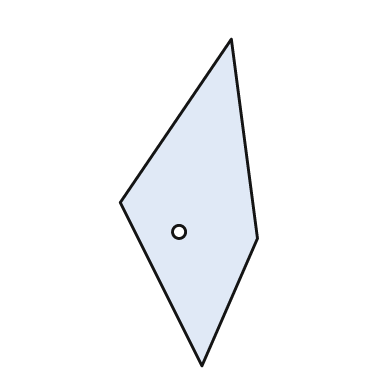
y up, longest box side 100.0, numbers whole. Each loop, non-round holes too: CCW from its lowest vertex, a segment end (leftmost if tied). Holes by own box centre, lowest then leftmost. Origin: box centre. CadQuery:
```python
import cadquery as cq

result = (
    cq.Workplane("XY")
    .moveTo(4.0, -50.0)
    .lineTo(21.0, -11.0)
    .lineTo(13.0, 50.0)
    .lineTo(-21.0, 0.0)
    .close()
    .moveTo(-3.0, -9.0)
    .circle(2.0)
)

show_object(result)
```